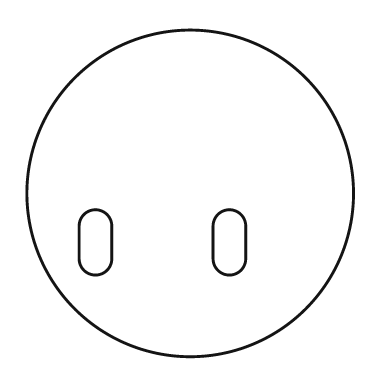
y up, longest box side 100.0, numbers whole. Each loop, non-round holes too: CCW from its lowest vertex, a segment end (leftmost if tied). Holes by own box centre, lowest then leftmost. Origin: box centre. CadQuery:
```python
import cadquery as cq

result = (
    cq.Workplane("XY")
    .moveTo(0.0, 0.0)
    .circle(50.0)
    .moveTo(-34.0, -20.0)
    .threePointArc((-29.0, -25.0), (-24.0, -20.0))
    .lineTo(-24.0, -10.0)
    .threePointArc((-29.0, -5.0), (-34.0, -10.0))
    .close()
    .moveTo(7.0, -20.0)
    .threePointArc((12.0, -25.0), (17.0, -20.0))
    .lineTo(17.0, -10.0)
    .threePointArc((12.0, -5.0), (7.0, -10.0))
    .close()
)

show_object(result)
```